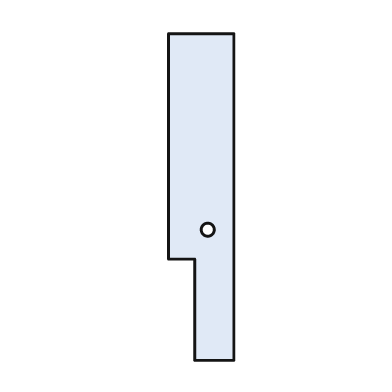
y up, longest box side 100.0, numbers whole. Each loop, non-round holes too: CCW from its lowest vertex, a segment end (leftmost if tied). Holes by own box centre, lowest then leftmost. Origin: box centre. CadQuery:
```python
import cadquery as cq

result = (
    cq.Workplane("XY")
    .moveTo(-2.0, -50.0)
    .lineTo(10.0, -50.0)
    .lineTo(10.0, 50.0)
    .lineTo(-10.0, 50.0)
    .lineTo(-10.0, -19.0)
    .lineTo(-2.0, -19.0)
    .close()
    .moveTo(2.0, -10.0)
    .circle(2.0)
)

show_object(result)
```